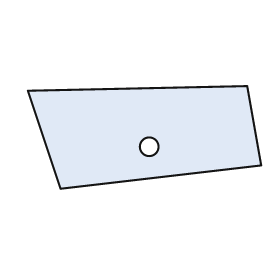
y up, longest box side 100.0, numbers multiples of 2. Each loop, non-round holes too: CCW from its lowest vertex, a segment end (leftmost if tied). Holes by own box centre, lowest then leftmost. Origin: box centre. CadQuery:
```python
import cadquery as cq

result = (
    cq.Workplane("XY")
    .moveTo(-36.0, -22.0)
    .lineTo(50.0, -12.0)
    .lineTo(44.0, 22.0)
    .lineTo(-50.0, 20.0)
    .close()
    .moveTo(2.0, -4.0)
    .circle(4.0)
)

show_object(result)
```